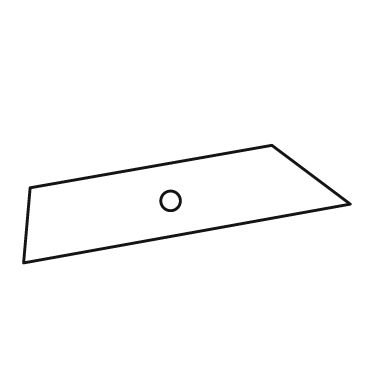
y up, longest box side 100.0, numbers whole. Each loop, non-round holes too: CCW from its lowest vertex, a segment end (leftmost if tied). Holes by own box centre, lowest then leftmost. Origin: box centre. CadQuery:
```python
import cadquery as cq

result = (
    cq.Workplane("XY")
    .moveTo(-50.0, -18.0)
    .lineTo(50.0, 0.0)
    .lineTo(26.0, 18.0)
    .lineTo(-48.0, 5.0)
    .close()
    .moveTo(-5.0, 1.0)
    .circle(3.0)
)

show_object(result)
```